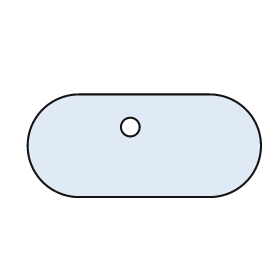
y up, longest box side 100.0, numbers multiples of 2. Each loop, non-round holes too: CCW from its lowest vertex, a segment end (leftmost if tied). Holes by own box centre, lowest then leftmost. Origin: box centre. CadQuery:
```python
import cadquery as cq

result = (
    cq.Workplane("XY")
    .moveTo(-28.0, -22.0)
    .lineTo(28.0, -22.0)
    .threePointArc((50.0, 0.0), (28.0, 22.0))
    .lineTo(-28.0, 22.0)
    .threePointArc((-50.0, 0.0), (-28.0, -22.0))
    .close()
    .moveTo(-6.0, 8.0)
    .circle(4.0)
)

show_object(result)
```